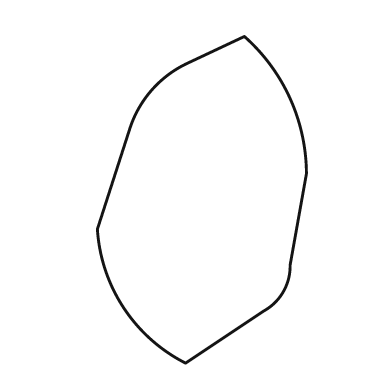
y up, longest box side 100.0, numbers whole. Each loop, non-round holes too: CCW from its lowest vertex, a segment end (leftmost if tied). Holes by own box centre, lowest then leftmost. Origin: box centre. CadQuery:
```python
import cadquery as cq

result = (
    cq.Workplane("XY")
    .moveTo(-5.0, -50.0)
    .lineTo(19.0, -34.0)
    .threePointArc((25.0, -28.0), (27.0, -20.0))
    .lineTo(32.0, 8.0)
    .threePointArc((27.0, 31.0), (13.0, 50.0))
    .lineTo(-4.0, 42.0)
    .threePointArc((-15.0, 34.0), (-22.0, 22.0))
    .lineTo(-32.0, -9.0)
    .threePointArc((-24.0, -33.0), (-5.0, -50.0))
    .close()
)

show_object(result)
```